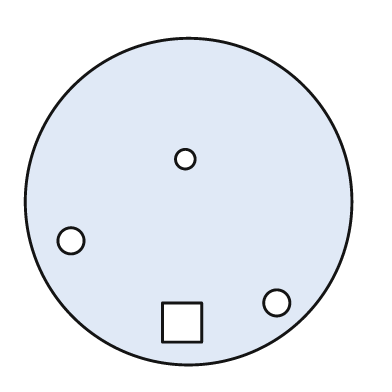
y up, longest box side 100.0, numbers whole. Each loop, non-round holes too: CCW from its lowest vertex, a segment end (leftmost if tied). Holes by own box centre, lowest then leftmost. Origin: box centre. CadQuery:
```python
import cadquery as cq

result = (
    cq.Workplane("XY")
    .moveTo(0.0, 0.0)
    .circle(50.0)
    .moveTo(-8.0, -43.0)
    .lineTo(4.0, -43.0)
    .lineTo(4.0, -31.0)
    .lineTo(-8.0, -31.0)
    .close()
    .moveTo(27.0, -31.0)
    .circle(4.0)
    .moveTo(-36.0, -12.0)
    .circle(4.0)
    .moveTo(-1.0, 13.0)
    .circle(3.0)
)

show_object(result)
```